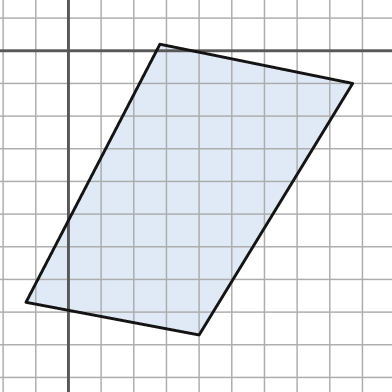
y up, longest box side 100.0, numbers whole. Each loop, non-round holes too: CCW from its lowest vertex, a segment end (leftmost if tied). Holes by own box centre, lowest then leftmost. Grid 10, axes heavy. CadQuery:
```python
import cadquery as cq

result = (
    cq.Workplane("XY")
    .moveTo(40.0, -87.0)
    .lineTo(87.0, -10.0)
    .lineTo(28.0, 2.0)
    .lineTo(-13.0, -77.0)
    .close()
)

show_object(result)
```